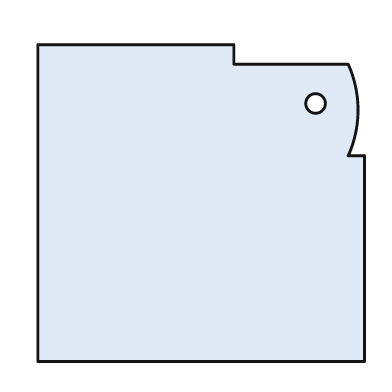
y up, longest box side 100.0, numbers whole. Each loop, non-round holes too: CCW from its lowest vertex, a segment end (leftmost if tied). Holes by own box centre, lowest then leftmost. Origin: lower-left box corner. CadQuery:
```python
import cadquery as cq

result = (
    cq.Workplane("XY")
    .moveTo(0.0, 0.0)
    .lineTo(100.0, 0.0)
    .lineTo(100.0, 63.0)
    .lineTo(95.0, 63.0)
    .threePointArc((98.0, 77.0), (95.0, 91.0))
    .lineTo(60.0, 91.0)
    .lineTo(60.0, 97.0)
    .lineTo(0.0, 97.0)
    .close()
    .moveTo(85.0, 79.0)
    .circle(3.0)
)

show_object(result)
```